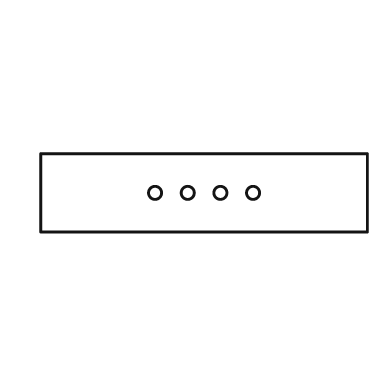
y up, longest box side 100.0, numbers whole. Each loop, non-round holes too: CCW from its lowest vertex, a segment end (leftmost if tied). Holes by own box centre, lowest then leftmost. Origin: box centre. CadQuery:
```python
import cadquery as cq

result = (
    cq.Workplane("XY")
    .moveTo(-50.0, -12.0)
    .lineTo(50.0, -12.0)
    .lineTo(50.0, 12.0)
    .lineTo(-50.0, 12.0)
    .close()
    .moveTo(-15.0, 0.0)
    .circle(2.0)
    .moveTo(-5.0, 0.0)
    .circle(2.0)
    .moveTo(5.0, 0.0)
    .circle(2.0)
    .moveTo(15.0, 0.0)
    .circle(2.0)
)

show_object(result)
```